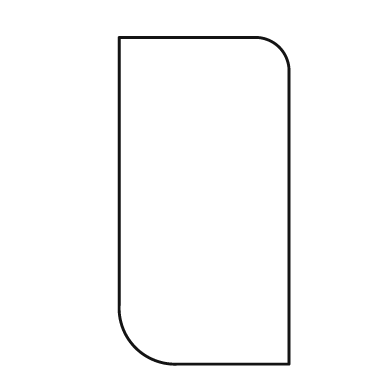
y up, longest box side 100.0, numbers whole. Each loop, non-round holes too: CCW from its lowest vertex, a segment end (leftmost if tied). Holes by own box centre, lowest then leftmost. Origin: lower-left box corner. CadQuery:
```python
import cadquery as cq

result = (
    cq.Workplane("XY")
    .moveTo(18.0, 0.0)
    .lineTo(52.0, 0.0)
    .lineTo(52.0, 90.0)
    .threePointArc((49.0, 97.0), (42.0, 100.0))
    .lineTo(0.0, 100.0)
    .lineTo(0.0, 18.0)
    .threePointArc((5.0, 5.0), (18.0, 0.0))
    .close()
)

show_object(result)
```